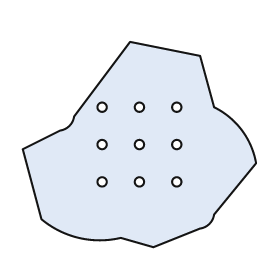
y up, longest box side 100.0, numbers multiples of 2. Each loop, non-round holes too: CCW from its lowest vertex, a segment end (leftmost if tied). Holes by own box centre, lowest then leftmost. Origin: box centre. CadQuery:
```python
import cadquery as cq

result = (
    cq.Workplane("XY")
    .moveTo(6.0, -44.0)
    .lineTo(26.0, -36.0)
    .threePointArc((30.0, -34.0), (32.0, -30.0))
    .lineTo(50.0, -8.0)
    .threePointArc((44.0, 6.0), (32.0, 16.0))
    .lineTo(26.0, 38.0)
    .lineTo(-4.0, 44.0)
    .lineTo(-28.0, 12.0)
    .threePointArc((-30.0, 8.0), (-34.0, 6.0))
    .lineTo(-50.0, -2.0)
    .lineTo(-42.0, -32.0)
    .threePointArc((-26.0, -40.0), (-8.0, -40.0))
    .close()
    .moveTo(-16.0, -16.0)
    .circle(2.0)
    .moveTo(0.0, -16.0)
    .circle(2.0)
    .moveTo(16.0, -16.0)
    .circle(2.0)
    .moveTo(-16.0, 0.0)
    .circle(2.0)
    .moveTo(0.0, 0.0)
    .circle(2.0)
    .moveTo(16.0, 0.0)
    .circle(2.0)
    .moveTo(-16.0, 16.0)
    .circle(2.0)
    .moveTo(0.0, 16.0)
    .circle(2.0)
    .moveTo(16.0, 16.0)
    .circle(2.0)
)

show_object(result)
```